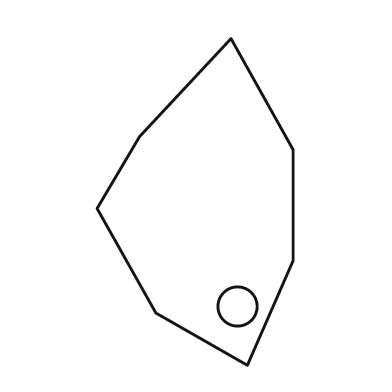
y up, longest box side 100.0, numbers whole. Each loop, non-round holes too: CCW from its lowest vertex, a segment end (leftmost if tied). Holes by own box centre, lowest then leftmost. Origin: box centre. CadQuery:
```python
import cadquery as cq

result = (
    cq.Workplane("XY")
    .moveTo(16.0, -50.0)
    .lineTo(30.0, -18.0)
    .lineTo(30.0, 16.0)
    .lineTo(11.0, 50.0)
    .lineTo(-17.0, 20.0)
    .lineTo(-30.0, -2.0)
    .lineTo(-12.0, -34.0)
    .close()
    .moveTo(13.0, -32.0)
    .circle(6.0)
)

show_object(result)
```